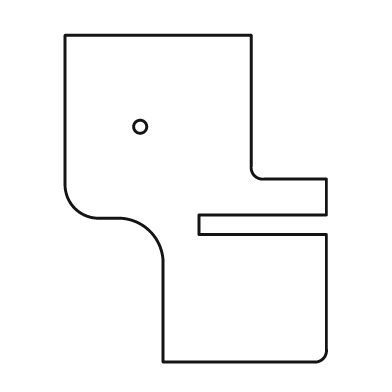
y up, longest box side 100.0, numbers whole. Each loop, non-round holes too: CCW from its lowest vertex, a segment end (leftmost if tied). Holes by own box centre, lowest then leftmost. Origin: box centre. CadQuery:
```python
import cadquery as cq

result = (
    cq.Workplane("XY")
    .moveTo(-10.0, -50.0)
    .lineTo(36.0, -50.0)
    .threePointArc((39.0, -49.0), (40.0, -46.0))
    .lineTo(40.0, -11.0)
    .lineTo(1.0, -11.0)
    .lineTo(1.0, -5.0)
    .lineTo(40.0, -5.0)
    .lineTo(40.0, 6.0)
    .lineTo(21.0, 6.0)
    .threePointArc((18.0, 7.0), (17.0, 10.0))
    .lineTo(17.0, 50.0)
    .lineTo(-40.0, 50.0)
    .lineTo(-40.0, 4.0)
    .threePointArc((-37.0, -3.0), (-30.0, -6.0))
    .lineTo(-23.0, -6.0)
    .threePointArc((-14.0, -10.0), (-10.0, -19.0))
    .close()
    .moveTo(-17.0, 22.0)
    .circle(2.0)
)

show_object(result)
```